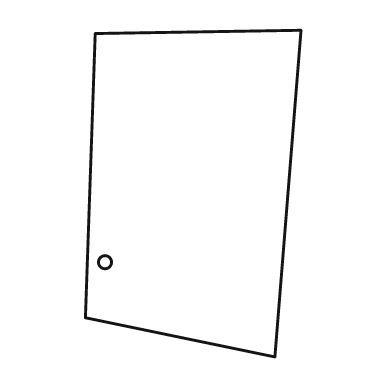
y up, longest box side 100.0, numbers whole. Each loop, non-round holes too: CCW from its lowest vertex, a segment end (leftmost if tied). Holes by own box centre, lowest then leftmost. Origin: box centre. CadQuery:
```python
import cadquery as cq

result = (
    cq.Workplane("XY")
    .moveTo(25.0, -50.0)
    .lineTo(33.0, 50.0)
    .lineTo(-30.0, 49.0)
    .lineTo(-33.0, -38.0)
    .close()
    .moveTo(-27.0, -21.0)
    .circle(2.0)
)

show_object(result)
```